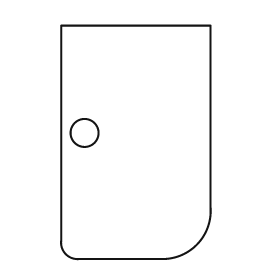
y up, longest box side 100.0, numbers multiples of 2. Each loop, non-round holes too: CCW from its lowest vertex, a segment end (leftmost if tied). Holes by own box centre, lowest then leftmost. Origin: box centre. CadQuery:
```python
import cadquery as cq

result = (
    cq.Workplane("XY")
    .moveTo(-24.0, -50.0)
    .lineTo(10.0, -50.0)
    .threePointArc((26.0, -44.0), (32.0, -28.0))
    .lineTo(32.0, 50.0)
    .lineTo(-32.0, 50.0)
    .lineTo(-32.0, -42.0)
    .threePointArc((-30.0, -48.0), (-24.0, -50.0))
    .close()
    .moveTo(-22.0, 4.0)
    .circle(6.0)
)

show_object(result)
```